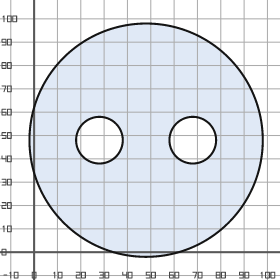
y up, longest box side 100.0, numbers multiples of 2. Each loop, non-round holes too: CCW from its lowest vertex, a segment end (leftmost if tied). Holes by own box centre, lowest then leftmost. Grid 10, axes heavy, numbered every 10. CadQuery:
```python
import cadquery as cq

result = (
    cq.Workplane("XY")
    .moveTo(48.0, 48.0)
    .circle(50.0)
    .moveTo(28.0, 48.0)
    .circle(10.0)
    .moveTo(68.0, 48.0)
    .circle(10.0)
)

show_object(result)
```